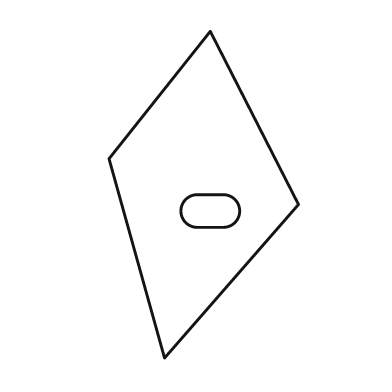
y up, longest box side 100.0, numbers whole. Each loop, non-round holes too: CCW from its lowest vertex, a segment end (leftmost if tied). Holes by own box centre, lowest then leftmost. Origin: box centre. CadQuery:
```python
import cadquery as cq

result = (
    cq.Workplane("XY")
    .moveTo(-12.0, -50.0)
    .lineTo(29.0, -3.0)
    .lineTo(2.0, 50.0)
    .lineTo(-29.0, 11.0)
    .close()
    .moveTo(-2.0, -10.0)
    .lineTo(6.0, -10.0)
    .threePointArc((11.0, -5.0), (6.0, 0.0))
    .lineTo(-2.0, 0.0)
    .threePointArc((-7.0, -5.0), (-2.0, -10.0))
    .close()
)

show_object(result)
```